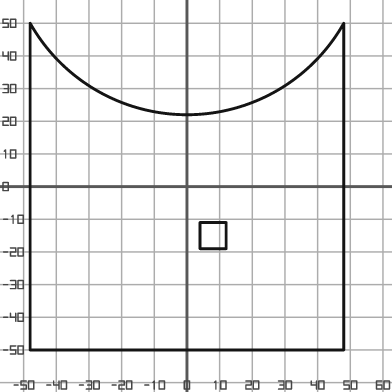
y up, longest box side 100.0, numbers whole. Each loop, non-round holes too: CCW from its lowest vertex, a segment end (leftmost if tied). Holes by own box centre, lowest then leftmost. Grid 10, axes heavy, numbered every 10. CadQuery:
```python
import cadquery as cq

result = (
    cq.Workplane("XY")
    .moveTo(-48.0, -50.0)
    .lineTo(48.0, -50.0)
    .lineTo(48.0, 50.0)
    .threePointArc((0.0, 22.0), (-48.0, 50.0))
    .close()
    .moveTo(4.0, -19.0)
    .lineTo(12.0, -19.0)
    .lineTo(12.0, -11.0)
    .lineTo(4.0, -11.0)
    .close()
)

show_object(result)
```